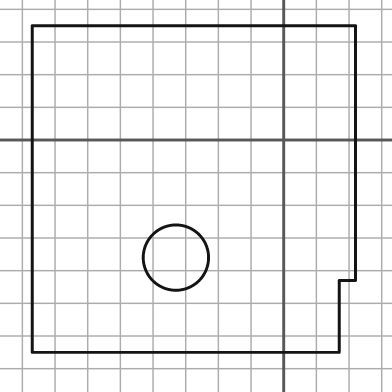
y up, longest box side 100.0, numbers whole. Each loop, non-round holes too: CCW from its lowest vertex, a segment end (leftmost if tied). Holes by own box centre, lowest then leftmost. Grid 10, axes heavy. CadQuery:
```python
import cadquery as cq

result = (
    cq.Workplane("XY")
    .moveTo(-77.0, -65.0)
    .lineTo(17.0, -65.0)
    .lineTo(17.0, -43.0)
    .lineTo(22.0, -43.0)
    .lineTo(22.0, 35.0)
    .lineTo(-77.0, 35.0)
    .close()
    .moveTo(-33.0, -36.0)
    .circle(10.0)
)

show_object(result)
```